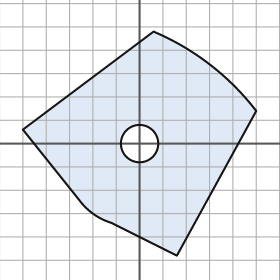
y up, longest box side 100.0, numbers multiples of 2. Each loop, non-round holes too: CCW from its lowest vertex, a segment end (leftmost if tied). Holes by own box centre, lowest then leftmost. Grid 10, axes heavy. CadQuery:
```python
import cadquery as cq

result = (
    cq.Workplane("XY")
    .moveTo(16.0, -48.0)
    .lineTo(50.0, 14.0)
    .threePointArc((30.0, 34.0), (6.0, 48.0))
    .lineTo(-50.0, 6.0)
    .lineTo(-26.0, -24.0)
    .threePointArc((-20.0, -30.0), (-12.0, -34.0))
    .close()
    .moveTo(0.0, 0.0)
    .circle(8.0)
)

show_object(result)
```